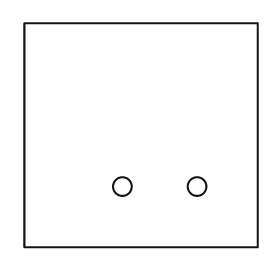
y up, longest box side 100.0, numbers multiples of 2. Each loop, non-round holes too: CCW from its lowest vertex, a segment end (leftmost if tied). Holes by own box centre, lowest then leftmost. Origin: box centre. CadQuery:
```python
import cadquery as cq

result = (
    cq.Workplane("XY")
    .moveTo(-50.0, -48.0)
    .lineTo(50.0, -48.0)
    .lineTo(50.0, 48.0)
    .lineTo(-50.0, 48.0)
    .close()
    .moveTo(-8.0, -22.0)
    .circle(4.0)
    .moveTo(24.0, -22.0)
    .circle(4.0)
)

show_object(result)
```